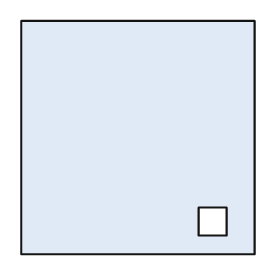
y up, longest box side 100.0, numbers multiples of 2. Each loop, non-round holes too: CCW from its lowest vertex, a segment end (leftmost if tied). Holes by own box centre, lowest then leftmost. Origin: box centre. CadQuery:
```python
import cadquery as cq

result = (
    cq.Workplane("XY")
    .moveTo(-50.0, -50.0)
    .lineTo(50.0, -50.0)
    .lineTo(50.0, 50.0)
    .lineTo(-50.0, 50.0)
    .close()
    .moveTo(26.0, -42.0)
    .lineTo(38.0, -42.0)
    .lineTo(38.0, -30.0)
    .lineTo(26.0, -30.0)
    .close()
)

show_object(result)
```